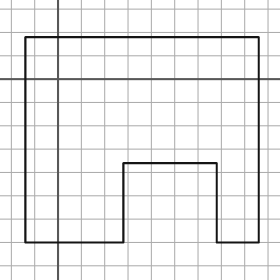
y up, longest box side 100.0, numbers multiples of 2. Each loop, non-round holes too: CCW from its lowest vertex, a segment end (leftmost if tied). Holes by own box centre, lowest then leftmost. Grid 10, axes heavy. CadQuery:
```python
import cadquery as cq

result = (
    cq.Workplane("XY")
    .moveTo(-14.0, -70.0)
    .lineTo(28.0, -70.0)
    .lineTo(28.0, -36.0)
    .lineTo(68.0, -36.0)
    .lineTo(68.0, -70.0)
    .lineTo(86.0, -70.0)
    .lineTo(86.0, 18.0)
    .lineTo(-14.0, 18.0)
    .close()
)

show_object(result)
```